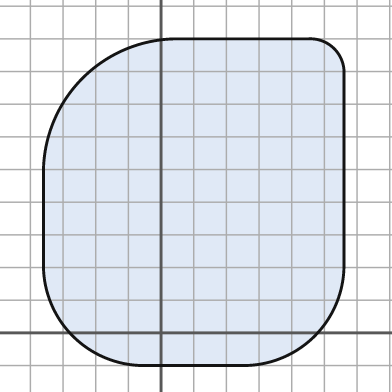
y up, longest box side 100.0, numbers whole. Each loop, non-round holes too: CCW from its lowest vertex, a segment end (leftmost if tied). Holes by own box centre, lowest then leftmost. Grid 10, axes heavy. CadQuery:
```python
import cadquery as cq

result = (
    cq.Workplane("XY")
    .moveTo(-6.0, -10.0)
    .lineTo(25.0, -10.0)
    .threePointArc((47.0, -1.0), (56.0, 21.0))
    .lineTo(56.0, 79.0)
    .threePointArc((53.0, 87.0), (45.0, 90.0))
    .lineTo(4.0, 90.0)
    .threePointArc((-24.0, 78.0), (-36.0, 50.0))
    .lineTo(-36.0, 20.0)
    .threePointArc((-27.0, -1.0), (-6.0, -10.0))
    .close()
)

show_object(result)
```